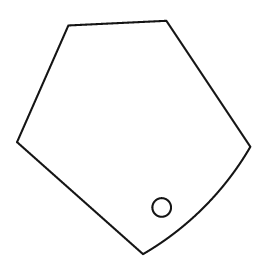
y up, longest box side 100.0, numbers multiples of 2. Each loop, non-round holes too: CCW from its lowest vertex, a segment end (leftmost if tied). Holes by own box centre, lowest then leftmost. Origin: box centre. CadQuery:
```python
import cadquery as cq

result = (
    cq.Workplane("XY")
    .moveTo(4.0, -50.0)
    .threePointArc((30.0, -30.0), (50.0, -4.0))
    .lineTo(14.0, 50.0)
    .lineTo(-28.0, 48.0)
    .lineTo(-50.0, -2.0)
    .close()
    .moveTo(12.0, -30.0)
    .circle(4.0)
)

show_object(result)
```